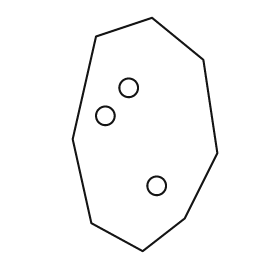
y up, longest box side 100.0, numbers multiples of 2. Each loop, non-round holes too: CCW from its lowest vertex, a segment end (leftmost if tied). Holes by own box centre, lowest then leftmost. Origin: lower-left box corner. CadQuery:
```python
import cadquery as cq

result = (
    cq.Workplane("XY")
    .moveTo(30.0, 0.0)
    .lineTo(48.0, 14.0)
    .lineTo(62.0, 42.0)
    .lineTo(56.0, 82.0)
    .lineTo(34.0, 100.0)
    .lineTo(10.0, 92.0)
    .lineTo(0.0, 48.0)
    .lineTo(8.0, 12.0)
    .close()
    .moveTo(36.0, 28.0)
    .circle(4.0)
    .moveTo(14.0, 58.0)
    .circle(4.0)
    .moveTo(24.0, 70.0)
    .circle(4.0)
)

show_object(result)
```